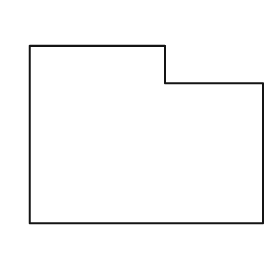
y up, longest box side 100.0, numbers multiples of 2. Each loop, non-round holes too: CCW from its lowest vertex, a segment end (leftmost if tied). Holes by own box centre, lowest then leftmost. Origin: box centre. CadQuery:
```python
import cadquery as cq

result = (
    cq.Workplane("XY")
    .moveTo(-50.0, -38.0)
    .lineTo(50.0, -38.0)
    .lineTo(50.0, 22.0)
    .lineTo(8.0, 22.0)
    .lineTo(8.0, 38.0)
    .lineTo(-50.0, 38.0)
    .close()
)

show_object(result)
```